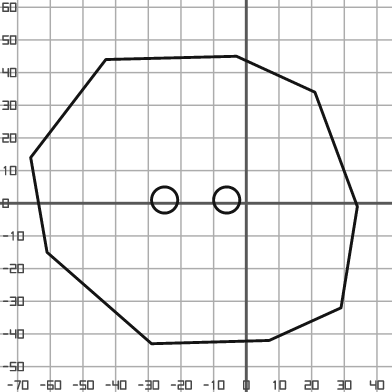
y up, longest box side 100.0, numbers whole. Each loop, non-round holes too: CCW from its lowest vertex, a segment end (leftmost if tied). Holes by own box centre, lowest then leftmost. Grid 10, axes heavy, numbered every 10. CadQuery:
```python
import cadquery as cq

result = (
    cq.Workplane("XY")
    .moveTo(-29.0, -43.0)
    .lineTo(7.0, -42.0)
    .lineTo(29.0, -32.0)
    .lineTo(34.0, -1.0)
    .lineTo(21.0, 34.0)
    .lineTo(-3.0, 45.0)
    .lineTo(-43.0, 44.0)
    .lineTo(-66.0, 14.0)
    .lineTo(-61.0, -15.0)
    .close()
    .moveTo(-25.0, 1.0)
    .circle(4.0)
    .moveTo(-6.0, 1.0)
    .circle(4.0)
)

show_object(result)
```